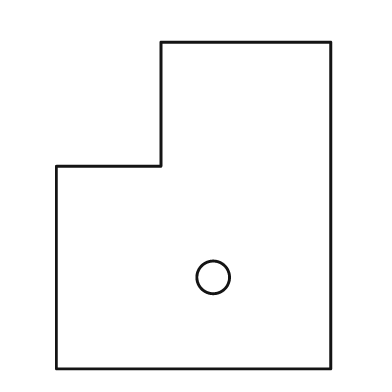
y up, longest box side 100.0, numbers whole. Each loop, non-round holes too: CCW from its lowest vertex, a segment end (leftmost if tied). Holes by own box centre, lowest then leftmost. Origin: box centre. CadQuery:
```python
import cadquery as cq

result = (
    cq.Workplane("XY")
    .moveTo(-42.0, -50.0)
    .lineTo(42.0, -50.0)
    .lineTo(42.0, 50.0)
    .lineTo(-10.0, 50.0)
    .lineTo(-10.0, 12.0)
    .lineTo(-42.0, 12.0)
    .close()
    .moveTo(6.0, -22.0)
    .circle(5.0)
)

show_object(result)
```